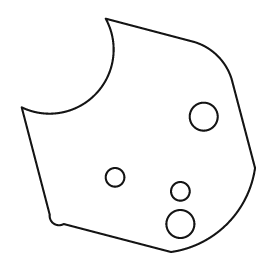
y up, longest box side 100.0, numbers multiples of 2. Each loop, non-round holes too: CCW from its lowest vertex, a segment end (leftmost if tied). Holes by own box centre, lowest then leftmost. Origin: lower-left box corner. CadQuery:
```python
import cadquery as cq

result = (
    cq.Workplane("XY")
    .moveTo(64.0, 0.0)
    .threePointArc((88.0, 12.0), (100.0, 36.0))
    .lineTo(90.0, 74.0)
    .threePointArc((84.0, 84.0), (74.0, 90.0))
    .lineTo(36.0, 100.0)
    .threePointArc((32.0, 68.0), (0.0, 62.0))
    .lineTo(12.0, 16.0)
    .threePointArc((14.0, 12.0), (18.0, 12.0))
    .close()
    .moveTo(68.0, 12.0)
    .circle(6.0)
    .moveTo(68.0, 26.0)
    .circle(4.0)
    .moveTo(40.0, 32.0)
    .circle(4.0)
    .moveTo(78.0, 58.0)
    .circle(6.0)
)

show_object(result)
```